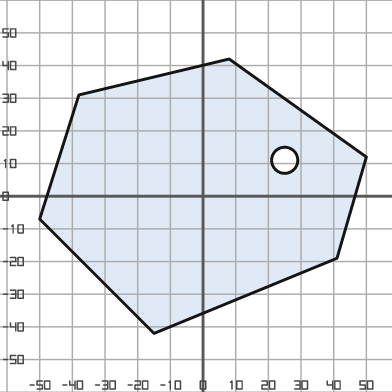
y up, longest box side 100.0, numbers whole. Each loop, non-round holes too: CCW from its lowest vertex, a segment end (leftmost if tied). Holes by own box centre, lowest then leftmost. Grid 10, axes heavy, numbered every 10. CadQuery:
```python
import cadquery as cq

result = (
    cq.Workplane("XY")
    .moveTo(-15.0, -42.0)
    .lineTo(41.0, -19.0)
    .lineTo(50.0, 12.0)
    .lineTo(8.0, 42.0)
    .lineTo(-38.0, 31.0)
    .lineTo(-50.0, -7.0)
    .close()
    .moveTo(25.0, 11.0)
    .circle(4.0)
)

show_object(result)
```